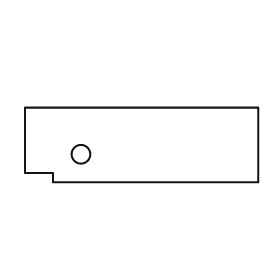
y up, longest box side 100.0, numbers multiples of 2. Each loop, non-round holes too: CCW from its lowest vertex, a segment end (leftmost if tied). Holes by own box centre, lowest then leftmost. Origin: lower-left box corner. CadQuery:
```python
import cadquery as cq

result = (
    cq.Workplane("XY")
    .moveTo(12.0, 0.0)
    .lineTo(100.0, 0.0)
    .lineTo(100.0, 32.0)
    .lineTo(0.0, 32.0)
    .lineTo(0.0, 4.0)
    .lineTo(12.0, 4.0)
    .close()
    .moveTo(24.0, 12.0)
    .circle(4.0)
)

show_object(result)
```